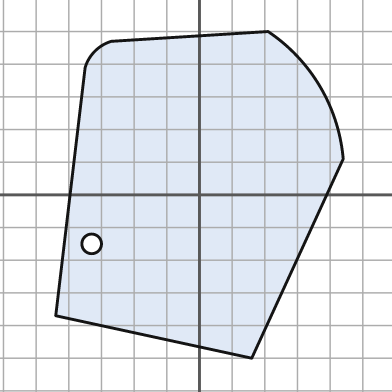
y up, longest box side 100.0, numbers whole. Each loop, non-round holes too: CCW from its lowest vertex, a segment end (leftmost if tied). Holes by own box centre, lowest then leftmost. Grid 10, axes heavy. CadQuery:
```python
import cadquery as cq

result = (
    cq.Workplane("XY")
    .moveTo(16.0, -50.0)
    .lineTo(44.0, 11.0)
    .threePointArc((37.0, 33.0), (21.0, 50.0))
    .lineTo(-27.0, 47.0)
    .threePointArc((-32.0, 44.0), (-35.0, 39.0))
    .lineTo(-44.0, -37.0)
    .close()
    .moveTo(-33.0, -15.0)
    .circle(3.0)
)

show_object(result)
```